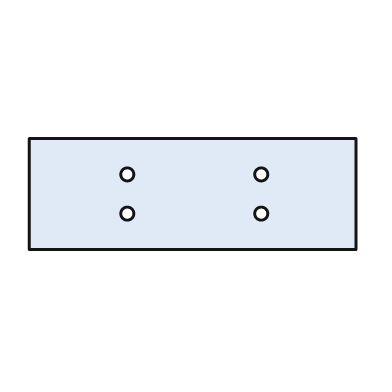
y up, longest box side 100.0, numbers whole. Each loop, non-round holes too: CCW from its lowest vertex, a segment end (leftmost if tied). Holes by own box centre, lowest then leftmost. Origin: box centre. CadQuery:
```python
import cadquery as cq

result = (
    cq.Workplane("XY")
    .moveTo(-50.0, -17.0)
    .lineTo(50.0, -17.0)
    .lineTo(50.0, 17.0)
    .lineTo(-50.0, 17.0)
    .close()
    .moveTo(-20.0, -6.0)
    .circle(2.0)
    .moveTo(21.0, -6.0)
    .circle(2.0)
    .moveTo(-20.0, 6.0)
    .circle(2.0)
    .moveTo(21.0, 6.0)
    .circle(2.0)
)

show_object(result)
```